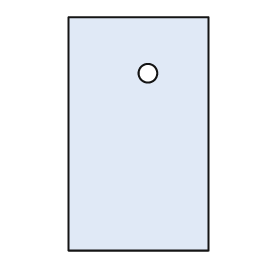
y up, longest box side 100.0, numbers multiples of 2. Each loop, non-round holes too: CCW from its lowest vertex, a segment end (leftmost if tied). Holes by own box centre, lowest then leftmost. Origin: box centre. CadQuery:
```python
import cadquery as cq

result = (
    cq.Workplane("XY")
    .moveTo(-30.0, -50.0)
    .lineTo(30.0, -50.0)
    .lineTo(30.0, 50.0)
    .lineTo(-30.0, 50.0)
    .close()
    .moveTo(4.0, 26.0)
    .circle(4.0)
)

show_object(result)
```